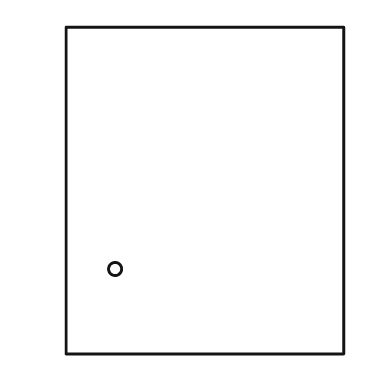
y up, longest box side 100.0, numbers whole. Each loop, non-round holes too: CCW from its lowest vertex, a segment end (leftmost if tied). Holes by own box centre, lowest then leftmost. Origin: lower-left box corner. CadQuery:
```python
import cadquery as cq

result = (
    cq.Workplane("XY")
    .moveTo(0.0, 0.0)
    .lineTo(85.0, 0.0)
    .lineTo(85.0, 100.0)
    .lineTo(0.0, 100.0)
    .close()
    .moveTo(15.0, 26.0)
    .circle(2.0)
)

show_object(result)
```